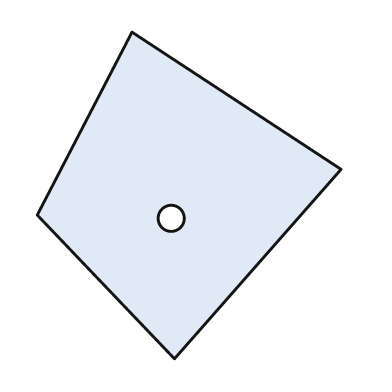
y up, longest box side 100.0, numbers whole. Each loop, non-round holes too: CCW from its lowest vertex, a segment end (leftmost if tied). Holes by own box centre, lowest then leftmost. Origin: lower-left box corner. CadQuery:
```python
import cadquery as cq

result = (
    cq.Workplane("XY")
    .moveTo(42.0, 0.0)
    .lineTo(93.0, 58.0)
    .lineTo(29.0, 100.0)
    .lineTo(0.0, 44.0)
    .close()
    .moveTo(41.0, 43.0)
    .circle(4.0)
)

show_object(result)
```